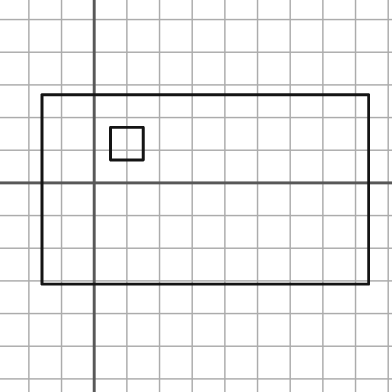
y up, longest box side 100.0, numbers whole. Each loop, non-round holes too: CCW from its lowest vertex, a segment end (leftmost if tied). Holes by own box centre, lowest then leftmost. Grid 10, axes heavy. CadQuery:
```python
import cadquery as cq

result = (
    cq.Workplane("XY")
    .moveTo(-16.0, -31.0)
    .lineTo(84.0, -31.0)
    .lineTo(84.0, 27.0)
    .lineTo(-16.0, 27.0)
    .close()
    .moveTo(5.0, 7.0)
    .lineTo(15.0, 7.0)
    .lineTo(15.0, 17.0)
    .lineTo(5.0, 17.0)
    .close()
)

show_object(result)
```